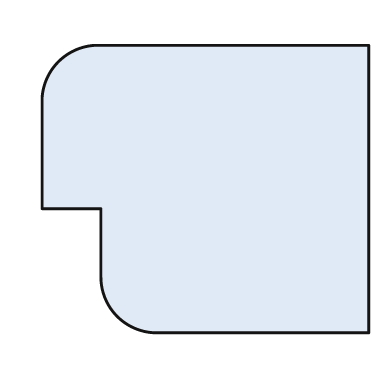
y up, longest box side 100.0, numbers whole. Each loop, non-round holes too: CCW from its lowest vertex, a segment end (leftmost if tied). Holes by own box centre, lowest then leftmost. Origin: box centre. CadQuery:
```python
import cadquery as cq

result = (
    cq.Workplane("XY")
    .moveTo(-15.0, -44.0)
    .lineTo(50.0, -44.0)
    .lineTo(50.0, 44.0)
    .lineTo(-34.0, 44.0)
    .threePointArc((-45.0, 39.0), (-50.0, 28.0))
    .lineTo(-50.0, -6.0)
    .lineTo(-32.0, -6.0)
    .lineTo(-32.0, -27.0)
    .threePointArc((-27.0, -39.0), (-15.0, -44.0))
    .close()
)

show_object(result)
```